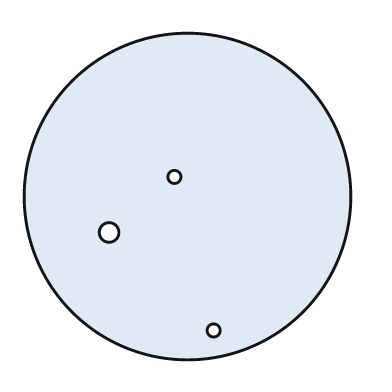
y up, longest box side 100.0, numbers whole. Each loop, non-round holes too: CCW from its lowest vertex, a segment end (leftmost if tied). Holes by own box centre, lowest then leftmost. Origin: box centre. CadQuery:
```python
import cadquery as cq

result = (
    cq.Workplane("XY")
    .moveTo(0.0, 0.0)
    .circle(50.0)
    .moveTo(8.0, -41.0)
    .circle(2.0)
    .moveTo(-24.0, -11.0)
    .circle(3.0)
    .moveTo(-4.0, 6.0)
    .circle(2.0)
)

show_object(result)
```